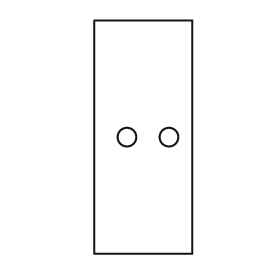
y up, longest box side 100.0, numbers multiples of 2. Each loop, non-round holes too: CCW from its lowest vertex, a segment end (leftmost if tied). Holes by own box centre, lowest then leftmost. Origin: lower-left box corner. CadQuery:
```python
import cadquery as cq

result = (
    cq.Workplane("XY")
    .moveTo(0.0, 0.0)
    .lineTo(42.0, 0.0)
    .lineTo(42.0, 100.0)
    .lineTo(0.0, 100.0)
    .close()
    .moveTo(14.0, 50.0)
    .circle(4.0)
    .moveTo(32.0, 50.0)
    .circle(4.0)
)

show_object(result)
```